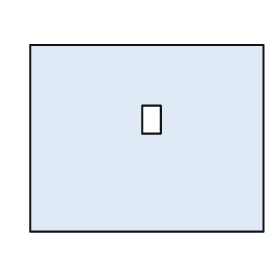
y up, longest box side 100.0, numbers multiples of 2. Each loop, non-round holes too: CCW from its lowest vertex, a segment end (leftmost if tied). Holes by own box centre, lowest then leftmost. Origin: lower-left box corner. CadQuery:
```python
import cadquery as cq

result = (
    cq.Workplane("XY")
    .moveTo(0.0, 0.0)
    .lineTo(100.0, 0.0)
    .lineTo(100.0, 80.0)
    .lineTo(0.0, 80.0)
    .close()
    .moveTo(48.0, 42.0)
    .lineTo(56.0, 42.0)
    .lineTo(56.0, 54.0)
    .lineTo(48.0, 54.0)
    .close()
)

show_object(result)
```